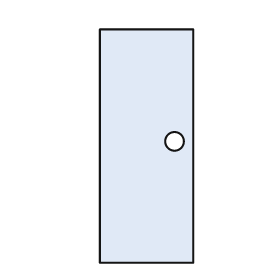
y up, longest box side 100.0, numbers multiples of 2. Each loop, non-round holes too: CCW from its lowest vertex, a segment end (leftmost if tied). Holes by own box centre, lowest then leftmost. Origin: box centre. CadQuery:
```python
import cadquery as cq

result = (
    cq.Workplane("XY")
    .moveTo(-20.0, -50.0)
    .lineTo(20.0, -50.0)
    .lineTo(20.0, 50.0)
    .lineTo(-20.0, 50.0)
    .close()
    .moveTo(12.0, 2.0)
    .circle(4.0)
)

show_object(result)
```